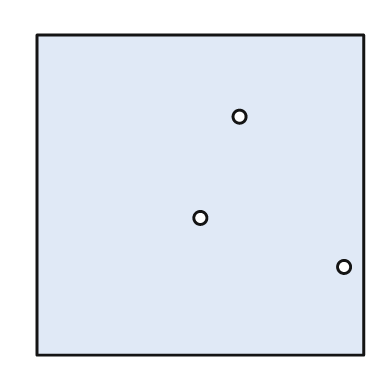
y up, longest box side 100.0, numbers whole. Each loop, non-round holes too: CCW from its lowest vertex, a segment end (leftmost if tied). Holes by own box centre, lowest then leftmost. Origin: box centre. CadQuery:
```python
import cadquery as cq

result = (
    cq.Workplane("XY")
    .moveTo(-50.0, -49.0)
    .lineTo(50.0, -49.0)
    .lineTo(50.0, 49.0)
    .lineTo(-50.0, 49.0)
    .close()
    .moveTo(44.0, -22.0)
    .circle(2.0)
    .moveTo(0.0, -7.0)
    .circle(2.0)
    .moveTo(12.0, 24.0)
    .circle(2.0)
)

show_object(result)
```